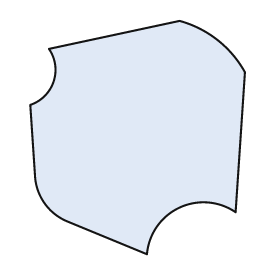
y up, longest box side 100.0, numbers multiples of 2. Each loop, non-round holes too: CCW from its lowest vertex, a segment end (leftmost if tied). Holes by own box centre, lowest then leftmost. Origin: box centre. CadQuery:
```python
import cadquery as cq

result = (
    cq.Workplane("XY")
    .moveTo(4.0, -50.0)
    .threePointArc((18.0, -30.0), (42.0, -32.0))
    .lineTo(46.0, 28.0)
    .threePointArc((34.0, 42.0), (18.0, 50.0))
    .lineTo(-38.0, 38.0)
    .threePointArc((-36.0, 24.0), (-46.0, 14.0))
    .lineTo(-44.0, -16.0)
    .threePointArc((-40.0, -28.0), (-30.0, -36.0))
    .close()
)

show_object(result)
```